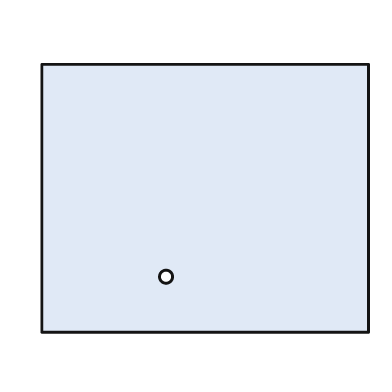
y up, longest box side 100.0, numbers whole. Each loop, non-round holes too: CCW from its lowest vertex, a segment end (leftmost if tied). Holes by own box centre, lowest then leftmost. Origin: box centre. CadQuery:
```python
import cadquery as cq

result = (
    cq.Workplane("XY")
    .moveTo(-50.0, -41.0)
    .lineTo(50.0, -41.0)
    .lineTo(50.0, 41.0)
    .lineTo(-50.0, 41.0)
    .close()
    .moveTo(-12.0, -24.0)
    .circle(2.0)
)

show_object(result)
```